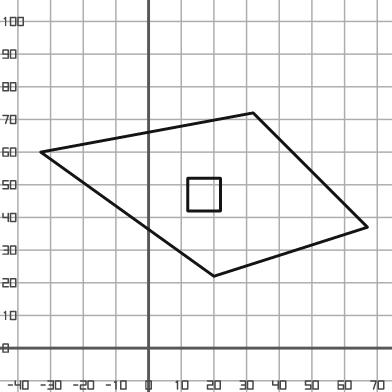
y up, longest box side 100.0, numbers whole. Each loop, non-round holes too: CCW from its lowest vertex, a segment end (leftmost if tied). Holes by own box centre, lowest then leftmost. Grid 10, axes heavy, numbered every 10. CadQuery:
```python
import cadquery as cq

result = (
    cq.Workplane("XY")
    .moveTo(20.0, 22.0)
    .lineTo(67.0, 37.0)
    .lineTo(32.0, 72.0)
    .lineTo(-33.0, 60.0)
    .close()
    .moveTo(12.0, 42.0)
    .lineTo(22.0, 42.0)
    .lineTo(22.0, 52.0)
    .lineTo(12.0, 52.0)
    .close()
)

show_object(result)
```